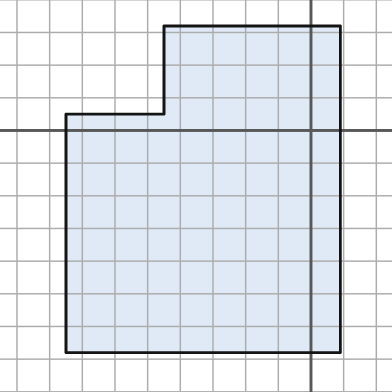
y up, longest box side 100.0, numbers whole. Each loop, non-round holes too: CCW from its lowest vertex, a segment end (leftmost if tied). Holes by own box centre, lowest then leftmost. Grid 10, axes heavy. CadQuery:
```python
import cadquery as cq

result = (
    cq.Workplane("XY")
    .moveTo(-75.0, -68.0)
    .lineTo(9.0, -68.0)
    .lineTo(9.0, 32.0)
    .lineTo(-45.0, 32.0)
    .lineTo(-45.0, 5.0)
    .lineTo(-75.0, 5.0)
    .close()
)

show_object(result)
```